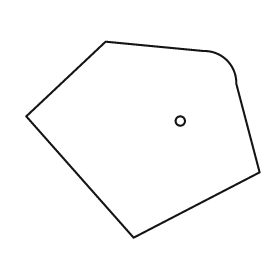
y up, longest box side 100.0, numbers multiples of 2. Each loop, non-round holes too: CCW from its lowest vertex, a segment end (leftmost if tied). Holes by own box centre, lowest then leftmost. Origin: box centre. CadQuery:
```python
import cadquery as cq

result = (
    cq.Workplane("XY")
    .moveTo(-4.0, -42.0)
    .lineTo(50.0, -14.0)
    .lineTo(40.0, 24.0)
    .threePointArc((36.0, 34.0), (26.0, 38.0))
    .lineTo(-16.0, 42.0)
    .lineTo(-50.0, 10.0)
    .close()
    .moveTo(16.0, 8.0)
    .circle(2.0)
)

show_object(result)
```